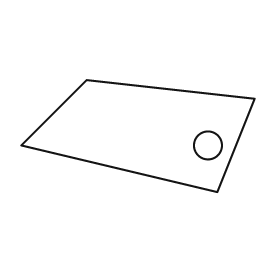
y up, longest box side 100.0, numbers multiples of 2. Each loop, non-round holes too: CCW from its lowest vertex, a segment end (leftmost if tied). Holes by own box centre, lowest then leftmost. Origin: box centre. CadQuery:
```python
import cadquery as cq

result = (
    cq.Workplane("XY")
    .moveTo(34.0, -24.0)
    .lineTo(50.0, 16.0)
    .lineTo(-22.0, 24.0)
    .lineTo(-50.0, -4.0)
    .close()
    .moveTo(30.0, -4.0)
    .circle(6.0)
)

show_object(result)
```